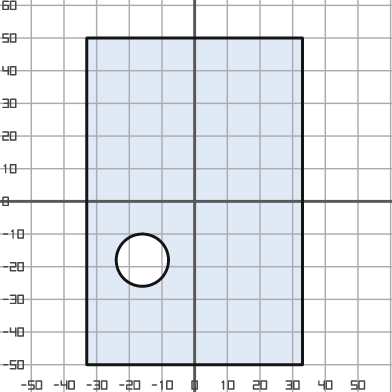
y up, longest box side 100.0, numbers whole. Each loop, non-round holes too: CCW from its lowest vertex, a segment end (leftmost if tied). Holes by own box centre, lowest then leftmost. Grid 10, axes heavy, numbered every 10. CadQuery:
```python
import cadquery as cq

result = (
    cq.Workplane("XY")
    .moveTo(-33.0, -50.0)
    .lineTo(33.0, -50.0)
    .lineTo(33.0, 50.0)
    .lineTo(-33.0, 50.0)
    .close()
    .moveTo(-16.0, -18.0)
    .circle(8.0)
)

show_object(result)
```